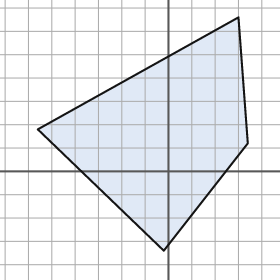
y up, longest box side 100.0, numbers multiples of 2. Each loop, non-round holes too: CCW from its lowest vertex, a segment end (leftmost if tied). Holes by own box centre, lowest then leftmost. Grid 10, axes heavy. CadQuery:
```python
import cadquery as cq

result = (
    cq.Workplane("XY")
    .moveTo(-2.0, -34.0)
    .lineTo(34.0, 12.0)
    .lineTo(30.0, 66.0)
    .lineTo(-56.0, 18.0)
    .close()
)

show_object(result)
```